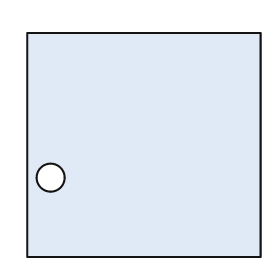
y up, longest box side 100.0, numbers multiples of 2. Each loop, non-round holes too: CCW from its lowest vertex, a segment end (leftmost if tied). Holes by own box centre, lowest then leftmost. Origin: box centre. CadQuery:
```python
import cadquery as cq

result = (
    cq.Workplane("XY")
    .moveTo(-50.0, -48.0)
    .lineTo(50.0, -48.0)
    .lineTo(50.0, 48.0)
    .lineTo(-50.0, 48.0)
    .close()
    .moveTo(-40.0, -14.0)
    .circle(6.0)
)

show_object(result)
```